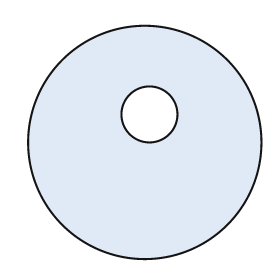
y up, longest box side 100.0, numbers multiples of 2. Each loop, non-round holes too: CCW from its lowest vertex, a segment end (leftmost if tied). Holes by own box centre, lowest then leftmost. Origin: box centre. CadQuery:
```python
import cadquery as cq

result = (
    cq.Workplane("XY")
    .moveTo(0.0, 0.0)
    .circle(50.0)
    .moveTo(2.0, 12.0)
    .circle(12.0)
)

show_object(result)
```